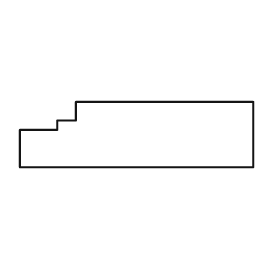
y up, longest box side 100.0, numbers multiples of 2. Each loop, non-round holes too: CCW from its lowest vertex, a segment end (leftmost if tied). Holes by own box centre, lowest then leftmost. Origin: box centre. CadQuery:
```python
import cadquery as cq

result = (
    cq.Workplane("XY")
    .moveTo(-50.0, -14.0)
    .lineTo(50.0, -14.0)
    .lineTo(50.0, 14.0)
    .lineTo(-26.0, 14.0)
    .lineTo(-26.0, 6.0)
    .lineTo(-34.0, 6.0)
    .lineTo(-34.0, 2.0)
    .lineTo(-50.0, 2.0)
    .close()
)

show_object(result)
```